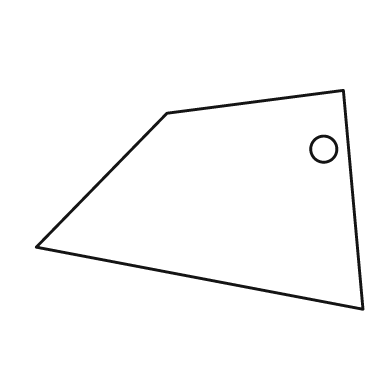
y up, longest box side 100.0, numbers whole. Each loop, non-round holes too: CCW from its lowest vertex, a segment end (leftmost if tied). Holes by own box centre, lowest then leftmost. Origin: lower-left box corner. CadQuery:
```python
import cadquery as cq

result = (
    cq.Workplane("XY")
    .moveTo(100.0, 0.0)
    .lineTo(94.0, 67.0)
    .lineTo(40.0, 60.0)
    .lineTo(0.0, 19.0)
    .close()
    .moveTo(88.0, 49.0)
    .circle(4.0)
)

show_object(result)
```